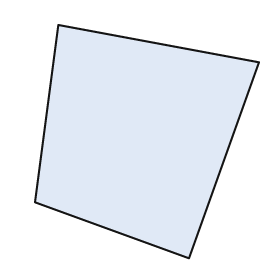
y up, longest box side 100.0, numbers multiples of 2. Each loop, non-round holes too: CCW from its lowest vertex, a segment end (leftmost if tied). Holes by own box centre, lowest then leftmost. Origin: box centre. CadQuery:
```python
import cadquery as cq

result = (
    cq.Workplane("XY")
    .moveTo(18.0, -50.0)
    .lineTo(48.0, 34.0)
    .lineTo(-38.0, 50.0)
    .lineTo(-48.0, -26.0)
    .close()
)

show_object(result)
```